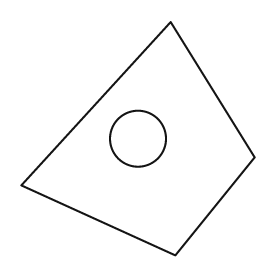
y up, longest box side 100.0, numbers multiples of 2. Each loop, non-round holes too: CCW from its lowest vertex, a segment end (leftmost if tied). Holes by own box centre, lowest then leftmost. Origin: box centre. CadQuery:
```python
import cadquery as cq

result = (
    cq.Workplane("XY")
    .moveTo(16.0, -50.0)
    .lineTo(50.0, -8.0)
    .lineTo(14.0, 50.0)
    .lineTo(-50.0, -20.0)
    .close()
    .moveTo(0.0, 0.0)
    .circle(12.0)
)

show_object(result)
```